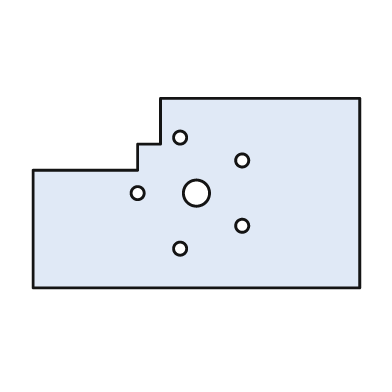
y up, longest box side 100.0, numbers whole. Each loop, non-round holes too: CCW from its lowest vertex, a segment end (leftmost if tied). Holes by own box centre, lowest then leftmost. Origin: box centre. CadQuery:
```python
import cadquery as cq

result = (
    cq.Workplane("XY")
    .moveTo(-50.0, -29.0)
    .lineTo(50.0, -29.0)
    .lineTo(50.0, 29.0)
    .lineTo(-11.0, 29.0)
    .lineTo(-11.0, 15.0)
    .lineTo(-18.0, 15.0)
    .lineTo(-18.0, 7.0)
    .lineTo(-50.0, 7.0)
    .close()
    .moveTo(-5.0, -17.0)
    .circle(2.0)
    .moveTo(14.0, -10.0)
    .circle(2.0)
    .moveTo(-18.0, 0.0)
    .circle(2.0)
    .moveTo(0.0, 0.0)
    .circle(4.0)
    .moveTo(14.0, 10.0)
    .circle(2.0)
    .moveTo(-5.0, 17.0)
    .circle(2.0)
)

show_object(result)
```